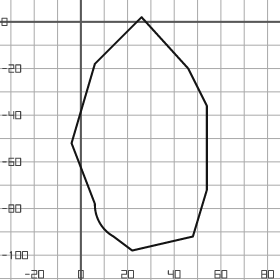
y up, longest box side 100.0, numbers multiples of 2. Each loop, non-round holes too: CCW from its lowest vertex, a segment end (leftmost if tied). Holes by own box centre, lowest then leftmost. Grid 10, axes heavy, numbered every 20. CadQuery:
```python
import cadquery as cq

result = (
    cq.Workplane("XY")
    .moveTo(22.0, -98.0)
    .lineTo(48.0, -92.0)
    .lineTo(54.0, -72.0)
    .lineTo(54.0, -36.0)
    .lineTo(46.0, -20.0)
    .lineTo(26.0, 2.0)
    .lineTo(6.0, -18.0)
    .lineTo(-4.0, -52.0)
    .lineTo(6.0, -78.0)
    .threePointArc((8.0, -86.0), (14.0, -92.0))
    .close()
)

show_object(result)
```